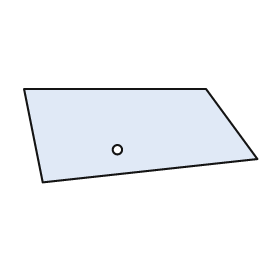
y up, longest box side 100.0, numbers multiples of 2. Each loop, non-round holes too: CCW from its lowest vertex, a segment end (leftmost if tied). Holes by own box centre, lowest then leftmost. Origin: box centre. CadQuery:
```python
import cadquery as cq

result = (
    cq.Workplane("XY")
    .moveTo(-42.0, -20.0)
    .lineTo(50.0, -10.0)
    .lineTo(28.0, 20.0)
    .lineTo(-50.0, 20.0)
    .close()
    .moveTo(-10.0, -6.0)
    .circle(2.0)
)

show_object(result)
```